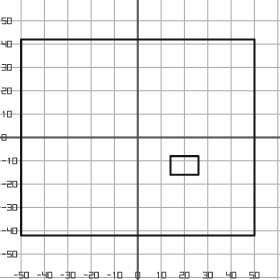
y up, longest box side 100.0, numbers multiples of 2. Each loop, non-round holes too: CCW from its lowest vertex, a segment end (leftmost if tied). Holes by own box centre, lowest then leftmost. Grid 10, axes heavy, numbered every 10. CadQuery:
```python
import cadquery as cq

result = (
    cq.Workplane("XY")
    .moveTo(-50.0, -42.0)
    .lineTo(50.0, -42.0)
    .lineTo(50.0, 42.0)
    .lineTo(-50.0, 42.0)
    .close()
    .moveTo(14.0, -16.0)
    .lineTo(26.0, -16.0)
    .lineTo(26.0, -8.0)
    .lineTo(14.0, -8.0)
    .close()
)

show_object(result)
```